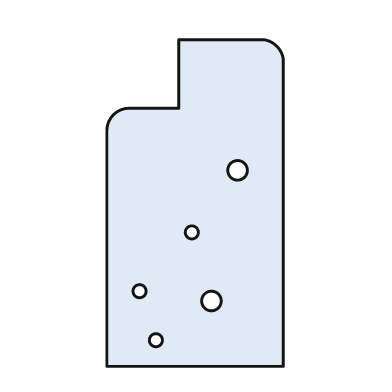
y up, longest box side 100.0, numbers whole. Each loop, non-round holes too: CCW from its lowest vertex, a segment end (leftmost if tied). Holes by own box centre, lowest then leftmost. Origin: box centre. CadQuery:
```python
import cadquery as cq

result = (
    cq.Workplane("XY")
    .moveTo(-27.0, -50.0)
    .lineTo(27.0, -50.0)
    .lineTo(27.0, 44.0)
    .threePointArc((25.0, 48.0), (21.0, 50.0))
    .lineTo(-5.0, 50.0)
    .lineTo(-5.0, 29.0)
    .lineTo(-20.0, 29.0)
    .threePointArc((-25.0, 27.0), (-27.0, 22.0))
    .close()
    .moveTo(-12.0, -42.0)
    .circle(2.0)
    .moveTo(5.0, -30.0)
    .circle(3.0)
    .moveTo(-17.0, -27.0)
    .circle(2.0)
    .moveTo(-1.0, -9.0)
    .circle(2.0)
    .moveTo(13.0, 10.0)
    .circle(3.0)
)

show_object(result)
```